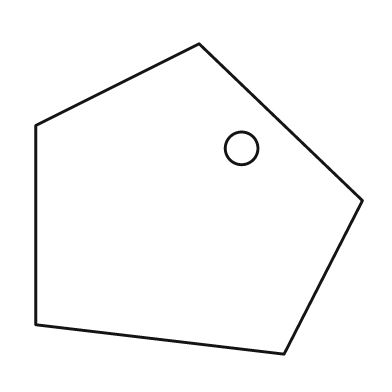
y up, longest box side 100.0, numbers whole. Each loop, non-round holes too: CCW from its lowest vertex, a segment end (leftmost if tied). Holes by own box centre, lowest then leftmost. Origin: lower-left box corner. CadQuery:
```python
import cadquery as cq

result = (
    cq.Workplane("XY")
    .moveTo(76.0, 0.0)
    .lineTo(100.0, 47.0)
    .lineTo(50.0, 95.0)
    .lineTo(0.0, 70.0)
    .lineTo(0.0, 9.0)
    .close()
    .moveTo(63.0, 63.0)
    .circle(5.0)
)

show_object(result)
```